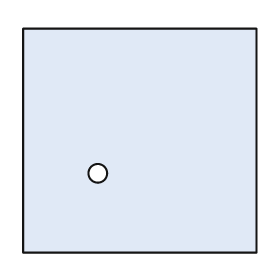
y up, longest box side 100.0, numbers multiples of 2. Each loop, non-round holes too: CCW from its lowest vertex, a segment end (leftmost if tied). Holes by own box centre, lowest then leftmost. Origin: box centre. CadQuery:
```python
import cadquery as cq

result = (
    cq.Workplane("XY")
    .moveTo(-50.0, -48.0)
    .lineTo(50.0, -48.0)
    .lineTo(50.0, 48.0)
    .lineTo(-50.0, 48.0)
    .close()
    .moveTo(-18.0, -14.0)
    .circle(4.0)
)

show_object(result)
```